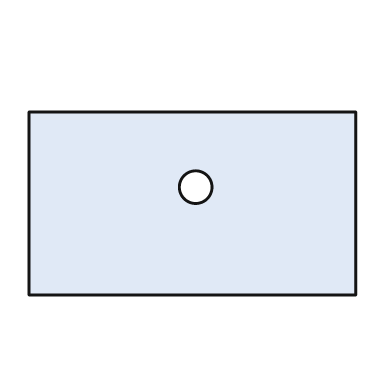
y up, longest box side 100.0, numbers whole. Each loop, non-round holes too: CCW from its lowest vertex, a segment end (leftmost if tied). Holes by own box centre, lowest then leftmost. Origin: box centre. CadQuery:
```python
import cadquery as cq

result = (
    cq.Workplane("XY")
    .moveTo(-50.0, -28.0)
    .lineTo(50.0, -28.0)
    .lineTo(50.0, 28.0)
    .lineTo(-50.0, 28.0)
    .close()
    .moveTo(1.0, 5.0)
    .circle(5.0)
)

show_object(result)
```